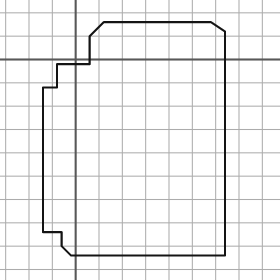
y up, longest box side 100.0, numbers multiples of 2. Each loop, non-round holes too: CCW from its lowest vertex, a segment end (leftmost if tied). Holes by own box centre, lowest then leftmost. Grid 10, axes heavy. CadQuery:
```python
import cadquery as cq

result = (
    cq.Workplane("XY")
    .moveTo(-2.0, -84.0)
    .lineTo(64.0, -84.0)
    .lineTo(64.0, 12.0)
    .lineTo(58.0, 16.0)
    .lineTo(12.0, 16.0)
    .lineTo(6.0, 10.0)
    .lineTo(6.0, -2.0)
    .lineTo(-8.0, -2.0)
    .lineTo(-8.0, -12.0)
    .lineTo(-14.0, -12.0)
    .lineTo(-14.0, -74.0)
    .lineTo(-6.0, -74.0)
    .lineTo(-6.0, -80.0)
    .close()
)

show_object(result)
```